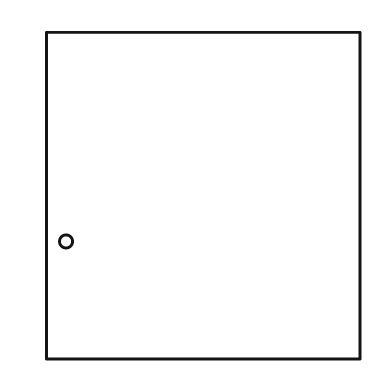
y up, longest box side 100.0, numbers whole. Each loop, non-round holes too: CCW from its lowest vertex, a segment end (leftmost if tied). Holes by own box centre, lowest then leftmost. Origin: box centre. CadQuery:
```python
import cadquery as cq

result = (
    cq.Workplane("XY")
    .moveTo(-48.0, -50.0)
    .lineTo(48.0, -50.0)
    .lineTo(48.0, 50.0)
    .lineTo(-48.0, 50.0)
    .close()
    .moveTo(-42.0, -14.0)
    .circle(2.0)
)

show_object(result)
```